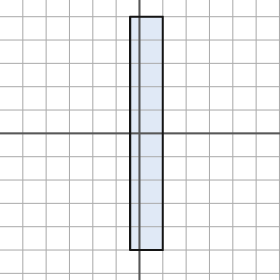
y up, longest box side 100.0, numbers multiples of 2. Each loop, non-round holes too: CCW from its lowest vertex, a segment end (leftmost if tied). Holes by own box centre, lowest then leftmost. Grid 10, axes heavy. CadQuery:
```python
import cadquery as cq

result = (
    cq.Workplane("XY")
    .moveTo(-4.0, -50.0)
    .lineTo(10.0, -50.0)
    .lineTo(10.0, 50.0)
    .lineTo(-4.0, 50.0)
    .close()
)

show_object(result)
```